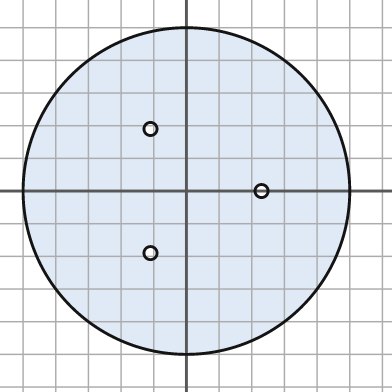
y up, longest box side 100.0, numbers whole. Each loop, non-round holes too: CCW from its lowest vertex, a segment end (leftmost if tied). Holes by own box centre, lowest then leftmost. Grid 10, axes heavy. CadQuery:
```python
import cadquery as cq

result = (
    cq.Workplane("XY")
    .moveTo(0.0, 0.0)
    .circle(50.0)
    .moveTo(-11.0, -19.0)
    .circle(2.0)
    .moveTo(23.0, 0.0)
    .circle(2.0)
    .moveTo(-11.0, 19.0)
    .circle(2.0)
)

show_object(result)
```